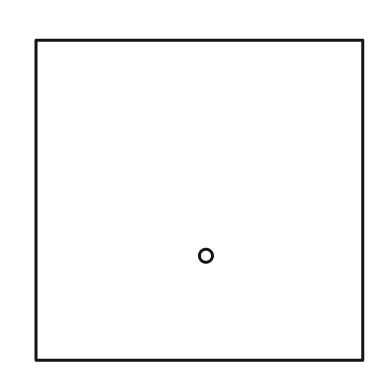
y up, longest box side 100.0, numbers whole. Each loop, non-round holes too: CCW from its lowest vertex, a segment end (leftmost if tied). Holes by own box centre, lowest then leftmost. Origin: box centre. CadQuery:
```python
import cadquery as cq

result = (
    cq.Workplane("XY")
    .moveTo(-50.0, -49.0)
    .lineTo(50.0, -49.0)
    .lineTo(50.0, 49.0)
    .lineTo(-50.0, 49.0)
    .close()
    .moveTo(2.0, -17.0)
    .circle(2.0)
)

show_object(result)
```